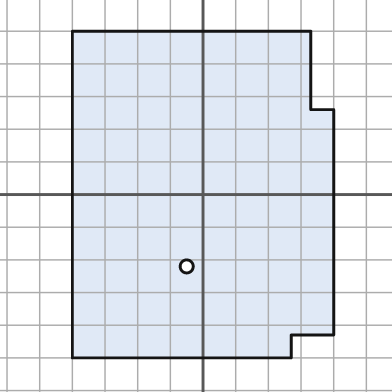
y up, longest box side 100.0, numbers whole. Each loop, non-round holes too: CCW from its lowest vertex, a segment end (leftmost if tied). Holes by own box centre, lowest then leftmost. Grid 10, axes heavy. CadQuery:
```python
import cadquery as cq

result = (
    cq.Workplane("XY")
    .moveTo(-40.0, -50.0)
    .lineTo(27.0, -50.0)
    .lineTo(27.0, -43.0)
    .lineTo(40.0, -43.0)
    .lineTo(40.0, 26.0)
    .lineTo(33.0, 26.0)
    .lineTo(33.0, 50.0)
    .lineTo(-40.0, 50.0)
    .close()
    .moveTo(-5.0, -22.0)
    .circle(2.0)
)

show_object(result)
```